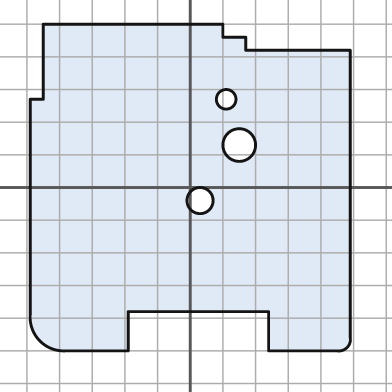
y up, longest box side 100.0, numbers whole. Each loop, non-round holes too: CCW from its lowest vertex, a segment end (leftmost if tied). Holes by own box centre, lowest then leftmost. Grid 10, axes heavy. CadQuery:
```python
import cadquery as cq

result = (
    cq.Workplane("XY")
    .moveTo(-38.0, -50.0)
    .lineTo(-19.0, -50.0)
    .lineTo(-19.0, -38.0)
    .lineTo(24.0, -38.0)
    .lineTo(24.0, -50.0)
    .lineTo(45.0, -50.0)
    .threePointArc((48.0, -49.0), (49.0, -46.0))
    .lineTo(49.0, 42.0)
    .lineTo(17.0, 42.0)
    .lineTo(17.0, 46.0)
    .lineTo(10.0, 46.0)
    .lineTo(10.0, 50.0)
    .lineTo(-45.0, 50.0)
    .lineTo(-45.0, 27.0)
    .lineTo(-49.0, 27.0)
    .lineTo(-49.0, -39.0)
    .threePointArc((-46.0, -47.0), (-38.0, -50.0))
    .close()
    .moveTo(3.0, -4.0)
    .circle(4.0)
    .moveTo(15.0, 13.0)
    .circle(5.0)
    .moveTo(11.0, 27.0)
    .circle(3.0)
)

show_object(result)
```